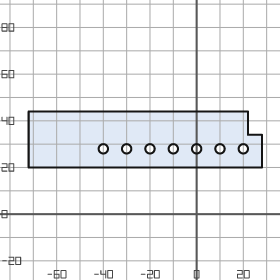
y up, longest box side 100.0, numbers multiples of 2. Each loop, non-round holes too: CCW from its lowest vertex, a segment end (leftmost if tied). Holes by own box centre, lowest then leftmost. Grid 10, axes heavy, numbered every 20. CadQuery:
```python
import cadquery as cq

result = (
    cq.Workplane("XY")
    .moveTo(-72.0, 20.0)
    .lineTo(28.0, 20.0)
    .lineTo(28.0, 34.0)
    .lineTo(22.0, 34.0)
    .lineTo(22.0, 44.0)
    .lineTo(-72.0, 44.0)
    .close()
    .moveTo(-40.0, 28.0)
    .circle(2.0)
    .moveTo(-30.0, 28.0)
    .circle(2.0)
    .moveTo(-20.0, 28.0)
    .circle(2.0)
    .moveTo(-10.0, 28.0)
    .circle(2.0)
    .moveTo(0.0, 28.0)
    .circle(2.0)
    .moveTo(10.0, 28.0)
    .circle(2.0)
    .moveTo(20.0, 28.0)
    .circle(2.0)
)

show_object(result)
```